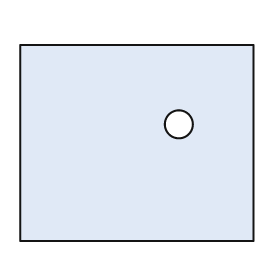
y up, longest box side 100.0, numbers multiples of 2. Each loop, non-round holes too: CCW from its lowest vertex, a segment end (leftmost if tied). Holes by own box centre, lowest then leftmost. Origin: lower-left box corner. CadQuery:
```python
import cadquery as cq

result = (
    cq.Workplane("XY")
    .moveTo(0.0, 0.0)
    .lineTo(100.0, 0.0)
    .lineTo(100.0, 84.0)
    .lineTo(0.0, 84.0)
    .close()
    .moveTo(68.0, 50.0)
    .circle(6.0)
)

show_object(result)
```